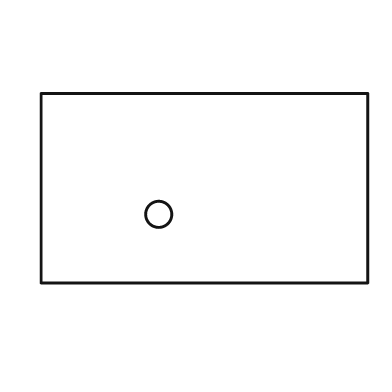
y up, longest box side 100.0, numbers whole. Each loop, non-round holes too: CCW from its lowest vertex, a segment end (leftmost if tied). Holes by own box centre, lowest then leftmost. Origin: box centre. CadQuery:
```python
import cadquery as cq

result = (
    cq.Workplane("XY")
    .moveTo(-50.0, -29.0)
    .lineTo(50.0, -29.0)
    .lineTo(50.0, 29.0)
    .lineTo(-50.0, 29.0)
    .close()
    .moveTo(-14.0, -8.0)
    .circle(4.0)
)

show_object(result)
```